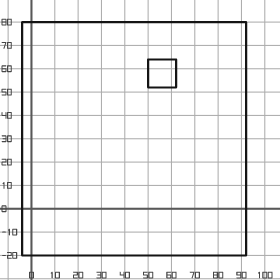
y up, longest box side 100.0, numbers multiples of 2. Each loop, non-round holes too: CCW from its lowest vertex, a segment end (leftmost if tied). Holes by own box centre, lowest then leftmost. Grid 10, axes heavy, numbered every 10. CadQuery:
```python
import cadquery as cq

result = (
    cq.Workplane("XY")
    .moveTo(-4.0, -20.0)
    .lineTo(92.0, -20.0)
    .lineTo(92.0, 80.0)
    .lineTo(-4.0, 80.0)
    .close()
    .moveTo(50.0, 52.0)
    .lineTo(62.0, 52.0)
    .lineTo(62.0, 64.0)
    .lineTo(50.0, 64.0)
    .close()
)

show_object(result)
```